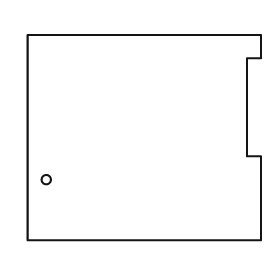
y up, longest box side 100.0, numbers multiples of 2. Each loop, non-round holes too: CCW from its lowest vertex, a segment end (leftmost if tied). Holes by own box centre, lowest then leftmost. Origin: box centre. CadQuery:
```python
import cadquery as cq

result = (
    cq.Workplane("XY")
    .moveTo(-50.0, -44.0)
    .lineTo(50.0, -44.0)
    .lineTo(50.0, -8.0)
    .lineTo(44.0, -8.0)
    .lineTo(44.0, 34.0)
    .lineTo(50.0, 34.0)
    .lineTo(50.0, 44.0)
    .lineTo(-50.0, 44.0)
    .close()
    .moveTo(-42.0, -18.0)
    .circle(2.0)
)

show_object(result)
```